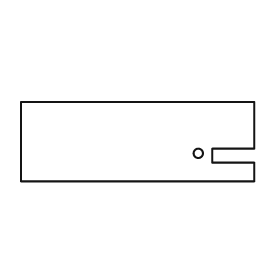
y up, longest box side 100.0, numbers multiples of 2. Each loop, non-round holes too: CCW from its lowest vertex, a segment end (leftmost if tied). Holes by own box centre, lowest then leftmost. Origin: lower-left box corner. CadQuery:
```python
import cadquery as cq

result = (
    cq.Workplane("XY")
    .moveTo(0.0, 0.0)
    .lineTo(100.0, 0.0)
    .lineTo(100.0, 8.0)
    .lineTo(82.0, 8.0)
    .lineTo(82.0, 14.0)
    .lineTo(100.0, 14.0)
    .lineTo(100.0, 34.0)
    .lineTo(0.0, 34.0)
    .close()
    .moveTo(76.0, 12.0)
    .circle(2.0)
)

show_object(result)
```